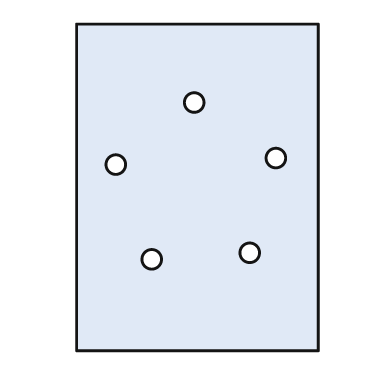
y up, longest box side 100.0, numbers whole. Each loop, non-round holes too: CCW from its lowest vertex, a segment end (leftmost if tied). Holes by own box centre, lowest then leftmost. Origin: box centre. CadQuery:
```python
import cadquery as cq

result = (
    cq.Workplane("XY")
    .moveTo(-37.0, -50.0)
    .lineTo(37.0, -50.0)
    .lineTo(37.0, 50.0)
    .lineTo(-37.0, 50.0)
    .close()
    .moveTo(-14.0, -22.0)
    .circle(3.0)
    .moveTo(16.0, -20.0)
    .circle(3.0)
    .moveTo(-25.0, 7.0)
    .circle(3.0)
    .moveTo(24.0, 9.0)
    .circle(3.0)
    .moveTo(-1.0, 26.0)
    .circle(3.0)
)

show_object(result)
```